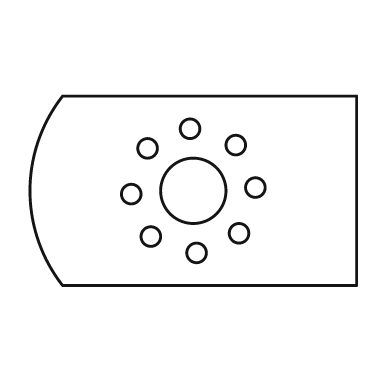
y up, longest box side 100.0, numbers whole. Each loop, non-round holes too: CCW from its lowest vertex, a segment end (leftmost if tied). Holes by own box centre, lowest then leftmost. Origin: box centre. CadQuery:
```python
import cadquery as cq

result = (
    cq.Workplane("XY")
    .moveTo(-40.0, -29.0)
    .lineTo(50.0, -29.0)
    .lineTo(50.0, 29.0)
    .lineTo(-40.0, 29.0)
    .threePointArc((-50.0, 0.0), (-40.0, -29.0))
    .close()
    .moveTo(1.0, -19.0)
    .circle(3.0)
    .moveTo(-13.0, -14.0)
    .circle(3.0)
    .moveTo(14.0, -13.0)
    .circle(3.0)
    .moveTo(-19.0, -1.0)
    .circle(3.0)
    .moveTo(0.0, 0.0)
    .circle(10.0)
    .moveTo(19.0, 1.0)
    .circle(3.0)
    .moveTo(-14.0, 13.0)
    .circle(3.0)
    .moveTo(13.0, 14.0)
    .circle(3.0)
    .moveTo(-1.0, 19.0)
    .circle(3.0)
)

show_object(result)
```